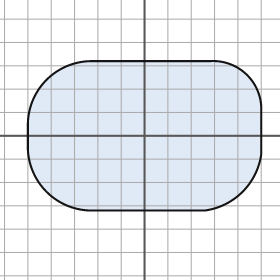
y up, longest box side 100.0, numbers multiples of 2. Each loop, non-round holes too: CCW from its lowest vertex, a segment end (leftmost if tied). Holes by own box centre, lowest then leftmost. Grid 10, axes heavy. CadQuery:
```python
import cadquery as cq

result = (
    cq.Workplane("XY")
    .moveTo(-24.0, -32.0)
    .lineTo(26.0, -32.0)
    .threePointArc((42.0, -24.0), (50.0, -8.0))
    .lineTo(50.0, 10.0)
    .threePointArc((44.0, 26.0), (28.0, 32.0))
    .lineTo(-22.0, 32.0)
    .threePointArc((-42.0, 24.0), (-50.0, 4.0))
    .lineTo(-50.0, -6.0)
    .threePointArc((-42.0, -24.0), (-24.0, -32.0))
    .close()
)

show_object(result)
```